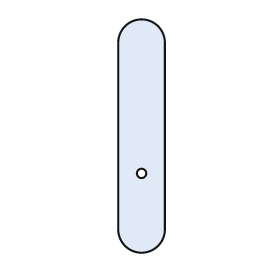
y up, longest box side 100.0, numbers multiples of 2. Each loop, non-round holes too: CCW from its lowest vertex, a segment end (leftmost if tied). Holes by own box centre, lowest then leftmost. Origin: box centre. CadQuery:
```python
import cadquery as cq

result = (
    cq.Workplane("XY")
    .moveTo(-10.0, -40.0)
    .threePointArc((0.0, -50.0), (10.0, -40.0))
    .lineTo(10.0, 40.0)
    .threePointArc((0.0, 50.0), (-10.0, 40.0))
    .close()
    .moveTo(0.0, -16.0)
    .circle(2.0)
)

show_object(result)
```